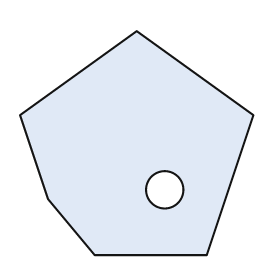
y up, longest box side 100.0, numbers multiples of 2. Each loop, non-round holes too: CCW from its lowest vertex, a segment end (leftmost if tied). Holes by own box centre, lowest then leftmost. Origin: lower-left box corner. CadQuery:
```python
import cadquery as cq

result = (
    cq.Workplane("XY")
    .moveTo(32.0, 0.0)
    .lineTo(80.0, 0.0)
    .lineTo(100.0, 60.0)
    .lineTo(50.0, 96.0)
    .lineTo(0.0, 60.0)
    .lineTo(12.0, 24.0)
    .close()
    .moveTo(62.0, 28.0)
    .circle(8.0)
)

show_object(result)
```